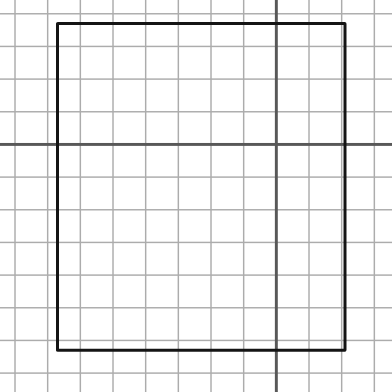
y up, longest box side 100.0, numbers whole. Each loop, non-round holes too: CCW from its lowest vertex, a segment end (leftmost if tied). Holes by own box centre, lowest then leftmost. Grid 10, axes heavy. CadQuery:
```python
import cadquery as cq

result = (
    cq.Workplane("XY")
    .moveTo(-67.0, -63.0)
    .lineTo(21.0, -63.0)
    .lineTo(21.0, 37.0)
    .lineTo(-67.0, 37.0)
    .close()
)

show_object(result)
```